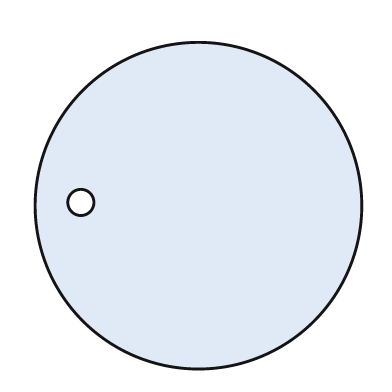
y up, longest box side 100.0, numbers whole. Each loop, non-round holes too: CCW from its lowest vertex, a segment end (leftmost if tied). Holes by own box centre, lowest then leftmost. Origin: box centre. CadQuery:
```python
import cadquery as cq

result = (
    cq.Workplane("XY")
    .moveTo(0.0, 0.0)
    .circle(50.0)
    .moveTo(-36.0, 1.0)
    .circle(4.0)
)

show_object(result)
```